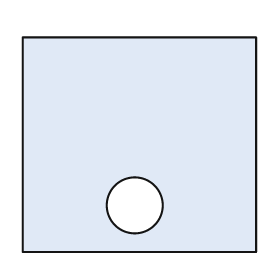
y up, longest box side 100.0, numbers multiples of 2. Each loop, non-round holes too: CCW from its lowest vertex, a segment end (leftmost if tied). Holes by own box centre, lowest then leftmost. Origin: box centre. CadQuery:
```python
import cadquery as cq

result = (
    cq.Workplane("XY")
    .moveTo(-50.0, -46.0)
    .lineTo(50.0, -46.0)
    .lineTo(50.0, 46.0)
    .lineTo(-50.0, 46.0)
    .close()
    .moveTo(-2.0, -26.0)
    .circle(12.0)
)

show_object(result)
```